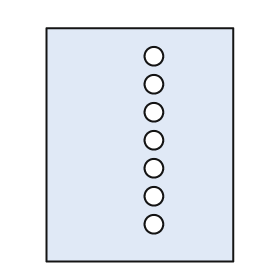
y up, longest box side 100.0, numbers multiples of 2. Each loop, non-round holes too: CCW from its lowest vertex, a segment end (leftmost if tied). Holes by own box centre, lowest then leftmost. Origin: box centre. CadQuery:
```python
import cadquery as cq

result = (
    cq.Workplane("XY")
    .moveTo(-40.0, -50.0)
    .lineTo(40.0, -50.0)
    .lineTo(40.0, 50.0)
    .lineTo(-40.0, 50.0)
    .close()
    .moveTo(6.0, -34.0)
    .circle(4.0)
    .moveTo(6.0, -22.0)
    .circle(4.0)
    .moveTo(6.0, -10.0)
    .circle(4.0)
    .moveTo(6.0, 2.0)
    .circle(4.0)
    .moveTo(6.0, 14.0)
    .circle(4.0)
    .moveTo(6.0, 26.0)
    .circle(4.0)
    .moveTo(6.0, 38.0)
    .circle(4.0)
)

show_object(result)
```